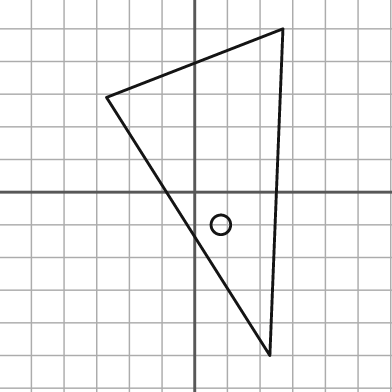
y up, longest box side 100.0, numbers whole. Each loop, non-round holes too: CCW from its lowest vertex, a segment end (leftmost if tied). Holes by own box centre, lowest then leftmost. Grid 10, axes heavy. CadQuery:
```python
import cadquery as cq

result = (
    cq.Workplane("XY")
    .moveTo(23.0, -50.0)
    .lineTo(27.0, 50.0)
    .lineTo(-27.0, 29.0)
    .close()
    .moveTo(8.0, -10.0)
    .circle(3.0)
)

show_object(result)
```